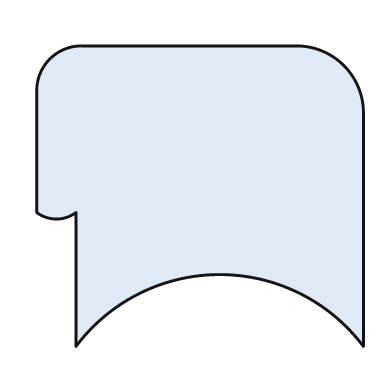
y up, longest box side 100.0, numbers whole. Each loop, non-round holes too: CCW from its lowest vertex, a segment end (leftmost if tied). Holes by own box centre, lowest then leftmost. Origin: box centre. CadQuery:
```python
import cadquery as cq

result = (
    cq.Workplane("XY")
    .moveTo(-38.0, -46.0)
    .threePointArc((6.0, -24.0), (50.0, -46.0))
    .lineTo(50.0, 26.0)
    .threePointArc((44.0, 40.0), (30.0, 46.0))
    .lineTo(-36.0, 46.0)
    .threePointArc((-46.0, 42.0), (-50.0, 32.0))
    .lineTo(-50.0, -5.0)
    .threePointArc((-44.0, -7.0), (-38.0, -5.0))
    .close()
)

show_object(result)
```